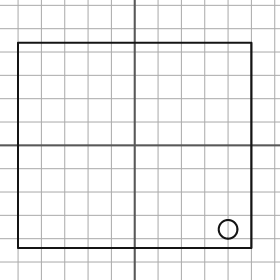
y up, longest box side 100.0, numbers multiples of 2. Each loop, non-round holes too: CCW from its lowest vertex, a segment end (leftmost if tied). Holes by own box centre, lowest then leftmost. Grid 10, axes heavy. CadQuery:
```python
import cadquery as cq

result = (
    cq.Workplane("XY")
    .moveTo(-50.0, -44.0)
    .lineTo(50.0, -44.0)
    .lineTo(50.0, 44.0)
    .lineTo(-50.0, 44.0)
    .close()
    .moveTo(40.0, -36.0)
    .circle(4.0)
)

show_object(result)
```